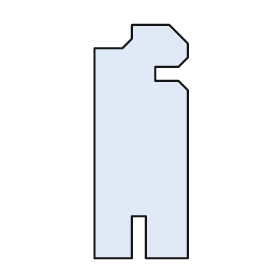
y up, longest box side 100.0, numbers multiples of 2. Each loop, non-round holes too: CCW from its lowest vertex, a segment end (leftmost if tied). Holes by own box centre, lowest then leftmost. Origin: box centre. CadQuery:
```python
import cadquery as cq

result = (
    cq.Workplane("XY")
    .moveTo(-20.0, -50.0)
    .lineTo(-4.0, -50.0)
    .lineTo(-4.0, -32.0)
    .lineTo(2.0, -32.0)
    .lineTo(2.0, -50.0)
    .lineTo(20.0, -50.0)
    .lineTo(20.0, 22.0)
    .lineTo(16.0, 26.0)
    .lineTo(6.0, 26.0)
    .lineTo(6.0, 32.0)
    .lineTo(16.0, 32.0)
    .lineTo(20.0, 36.0)
    .lineTo(20.0, 42.0)
    .lineTo(12.0, 50.0)
    .lineTo(-4.0, 50.0)
    .lineTo(-4.0, 44.0)
    .lineTo(-8.0, 40.0)
    .lineTo(-20.0, 40.0)
    .close()
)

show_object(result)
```